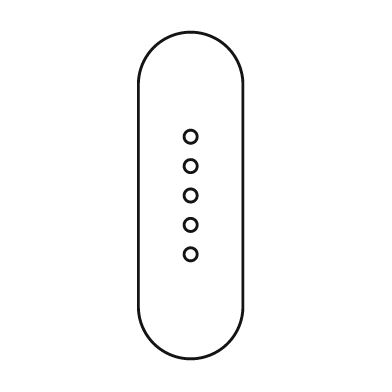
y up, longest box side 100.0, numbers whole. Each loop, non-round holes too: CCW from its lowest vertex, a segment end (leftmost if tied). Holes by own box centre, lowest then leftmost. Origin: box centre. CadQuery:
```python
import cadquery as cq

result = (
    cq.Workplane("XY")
    .moveTo(-16.0, -34.0)
    .threePointArc((0.0, -50.0), (16.0, -34.0))
    .lineTo(16.0, 34.0)
    .threePointArc((0.0, 50.0), (-16.0, 34.0))
    .close()
    .moveTo(0.0, -18.0)
    .circle(2.0)
    .moveTo(0.0, -9.0)
    .circle(2.0)
    .moveTo(0.0, 0.0)
    .circle(2.0)
    .moveTo(0.0, 9.0)
    .circle(2.0)
    .moveTo(0.0, 18.0)
    .circle(2.0)
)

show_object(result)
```